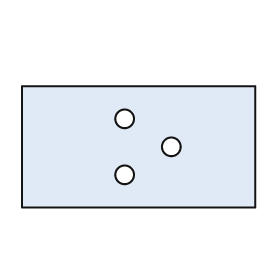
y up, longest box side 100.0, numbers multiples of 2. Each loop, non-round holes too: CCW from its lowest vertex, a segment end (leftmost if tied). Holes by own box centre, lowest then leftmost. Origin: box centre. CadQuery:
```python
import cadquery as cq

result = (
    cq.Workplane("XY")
    .moveTo(-50.0, -26.0)
    .lineTo(50.0, -26.0)
    .lineTo(50.0, 26.0)
    .lineTo(-50.0, 26.0)
    .close()
    .moveTo(-6.0, -12.0)
    .circle(4.0)
    .moveTo(14.0, 0.0)
    .circle(4.0)
    .moveTo(-6.0, 12.0)
    .circle(4.0)
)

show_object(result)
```